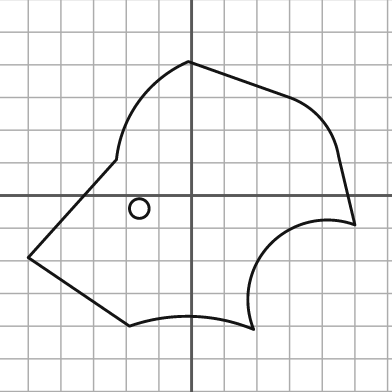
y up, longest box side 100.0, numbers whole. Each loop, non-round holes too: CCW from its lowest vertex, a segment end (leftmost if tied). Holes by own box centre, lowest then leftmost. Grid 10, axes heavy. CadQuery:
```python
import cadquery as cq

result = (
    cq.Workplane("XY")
    .moveTo(19.0, -41.0)
    .threePointArc((24.0, -15.0), (50.0, -9.0))
    .lineTo(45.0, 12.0)
    .threePointArc((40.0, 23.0), (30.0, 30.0))
    .lineTo(-1.0, 41.0)
    .threePointArc((-16.0, 29.0), (-23.0, 11.0))
    .lineTo(-50.0, -19.0)
    .lineTo(-19.0, -40.0)
    .threePointArc((0.0, -37.0), (19.0, -41.0))
    .close()
    .moveTo(-16.0, -4.0)
    .circle(3.0)
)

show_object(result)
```